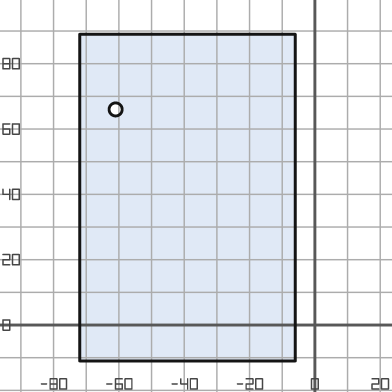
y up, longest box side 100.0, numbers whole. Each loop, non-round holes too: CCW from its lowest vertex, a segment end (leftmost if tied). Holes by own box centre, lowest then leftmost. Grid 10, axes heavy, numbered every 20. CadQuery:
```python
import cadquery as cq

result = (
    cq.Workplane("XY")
    .moveTo(-72.0, -11.0)
    .lineTo(-6.0, -11.0)
    .lineTo(-6.0, 89.0)
    .lineTo(-72.0, 89.0)
    .close()
    .moveTo(-61.0, 66.0)
    .circle(2.0)
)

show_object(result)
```